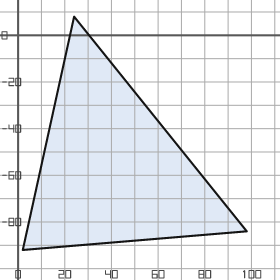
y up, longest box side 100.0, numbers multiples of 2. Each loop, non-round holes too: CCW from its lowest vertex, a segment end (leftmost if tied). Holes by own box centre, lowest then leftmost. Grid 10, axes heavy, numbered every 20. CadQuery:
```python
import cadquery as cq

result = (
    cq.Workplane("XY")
    .moveTo(2.0, -92.0)
    .lineTo(98.0, -84.0)
    .lineTo(24.0, 8.0)
    .close()
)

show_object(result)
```